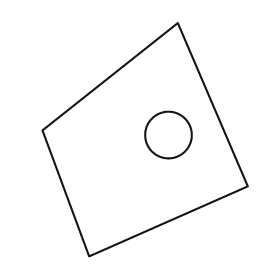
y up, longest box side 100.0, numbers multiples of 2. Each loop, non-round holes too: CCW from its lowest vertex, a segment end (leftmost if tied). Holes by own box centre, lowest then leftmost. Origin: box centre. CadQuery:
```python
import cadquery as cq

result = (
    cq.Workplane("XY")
    .moveTo(-24.0, -50.0)
    .lineTo(44.0, -20.0)
    .lineTo(14.0, 50.0)
    .lineTo(-44.0, 4.0)
    .close()
    .moveTo(10.0, 2.0)
    .circle(10.0)
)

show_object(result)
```